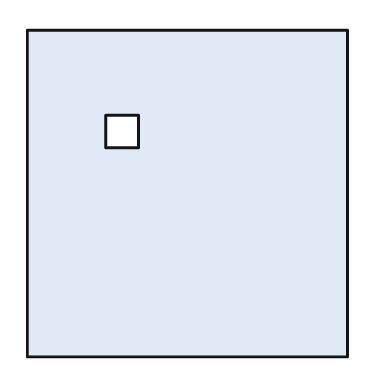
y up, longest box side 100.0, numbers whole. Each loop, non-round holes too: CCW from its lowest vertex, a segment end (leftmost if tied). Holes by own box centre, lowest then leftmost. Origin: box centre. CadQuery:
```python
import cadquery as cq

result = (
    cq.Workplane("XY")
    .moveTo(-49.0, -50.0)
    .lineTo(49.0, -50.0)
    .lineTo(49.0, 50.0)
    .lineTo(-49.0, 50.0)
    .close()
    .moveTo(-25.0, 14.0)
    .lineTo(-15.0, 14.0)
    .lineTo(-15.0, 24.0)
    .lineTo(-25.0, 24.0)
    .close()
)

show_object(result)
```